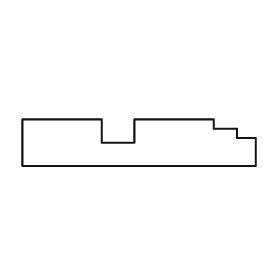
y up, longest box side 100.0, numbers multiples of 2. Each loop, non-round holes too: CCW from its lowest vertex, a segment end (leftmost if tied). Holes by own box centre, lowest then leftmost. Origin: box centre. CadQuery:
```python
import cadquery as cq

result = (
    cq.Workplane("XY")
    .moveTo(-50.0, -10.0)
    .lineTo(50.0, -10.0)
    .lineTo(50.0, 2.0)
    .lineTo(42.0, 2.0)
    .lineTo(42.0, 6.0)
    .lineTo(32.0, 6.0)
    .lineTo(32.0, 10.0)
    .lineTo(-2.0, 10.0)
    .lineTo(-2.0, 0.0)
    .lineTo(-16.0, 0.0)
    .lineTo(-16.0, 10.0)
    .lineTo(-50.0, 10.0)
    .close()
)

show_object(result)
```